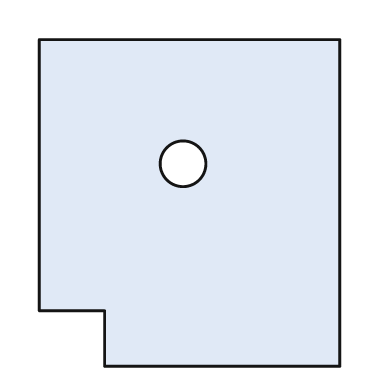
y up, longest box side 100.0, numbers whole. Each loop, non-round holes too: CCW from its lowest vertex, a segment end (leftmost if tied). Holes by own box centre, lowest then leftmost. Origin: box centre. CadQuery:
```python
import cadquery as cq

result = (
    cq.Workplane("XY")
    .moveTo(-26.0, -50.0)
    .lineTo(46.0, -50.0)
    .lineTo(46.0, 50.0)
    .lineTo(-46.0, 50.0)
    .lineTo(-46.0, -33.0)
    .lineTo(-26.0, -33.0)
    .close()
    .moveTo(-2.0, 12.0)
    .circle(7.0)
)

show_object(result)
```